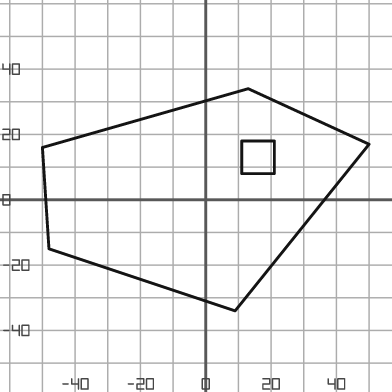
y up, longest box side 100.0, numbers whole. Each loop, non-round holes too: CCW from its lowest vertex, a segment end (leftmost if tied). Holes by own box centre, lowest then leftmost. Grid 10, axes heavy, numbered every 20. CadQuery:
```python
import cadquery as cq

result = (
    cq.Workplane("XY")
    .moveTo(9.0, -34.0)
    .lineTo(50.0, 17.0)
    .lineTo(13.0, 34.0)
    .lineTo(-50.0, 16.0)
    .lineTo(-48.0, -15.0)
    .close()
    .moveTo(11.0, 8.0)
    .lineTo(21.0, 8.0)
    .lineTo(21.0, 18.0)
    .lineTo(11.0, 18.0)
    .close()
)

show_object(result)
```